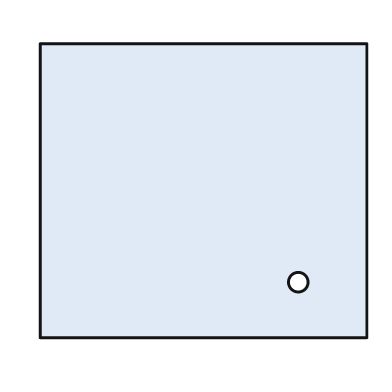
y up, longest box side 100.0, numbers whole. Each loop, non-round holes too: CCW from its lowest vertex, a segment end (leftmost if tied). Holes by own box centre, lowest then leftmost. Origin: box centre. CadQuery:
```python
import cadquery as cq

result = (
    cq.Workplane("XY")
    .moveTo(-50.0, -45.0)
    .lineTo(50.0, -45.0)
    .lineTo(50.0, 45.0)
    .lineTo(-50.0, 45.0)
    .close()
    .moveTo(29.0, -28.0)
    .circle(3.0)
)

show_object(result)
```